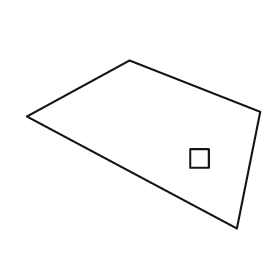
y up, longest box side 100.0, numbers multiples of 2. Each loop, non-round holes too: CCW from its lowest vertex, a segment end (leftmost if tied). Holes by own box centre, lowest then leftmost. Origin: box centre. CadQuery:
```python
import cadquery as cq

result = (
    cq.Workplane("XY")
    .moveTo(40.0, -36.0)
    .lineTo(50.0, 14.0)
    .lineTo(-6.0, 36.0)
    .lineTo(-50.0, 12.0)
    .close()
    .moveTo(20.0, -10.0)
    .lineTo(28.0, -10.0)
    .lineTo(28.0, -2.0)
    .lineTo(20.0, -2.0)
    .close()
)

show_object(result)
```